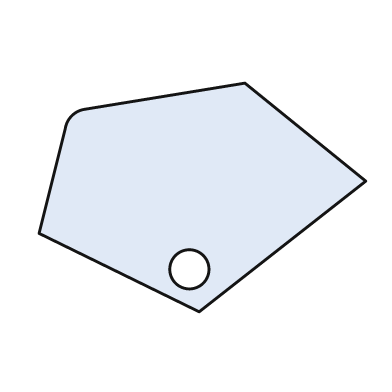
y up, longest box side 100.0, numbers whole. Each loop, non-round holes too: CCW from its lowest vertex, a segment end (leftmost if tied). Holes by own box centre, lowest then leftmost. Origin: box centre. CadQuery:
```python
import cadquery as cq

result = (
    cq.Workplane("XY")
    .moveTo(-1.0, -35.0)
    .lineTo(50.0, 5.0)
    .lineTo(13.0, 35.0)
    .lineTo(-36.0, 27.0)
    .threePointArc((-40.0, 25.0), (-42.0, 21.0))
    .lineTo(-50.0, -11.0)
    .close()
    .moveTo(-4.0, -22.0)
    .circle(6.0)
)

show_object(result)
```